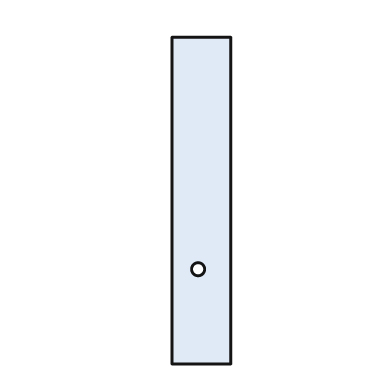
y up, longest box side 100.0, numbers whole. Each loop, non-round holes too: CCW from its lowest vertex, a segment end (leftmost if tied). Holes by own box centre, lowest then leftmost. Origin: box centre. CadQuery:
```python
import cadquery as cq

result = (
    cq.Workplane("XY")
    .moveTo(-9.0, -50.0)
    .lineTo(9.0, -50.0)
    .lineTo(9.0, 50.0)
    .lineTo(-9.0, 50.0)
    .close()
    .moveTo(-1.0, -21.0)
    .circle(2.0)
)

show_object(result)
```